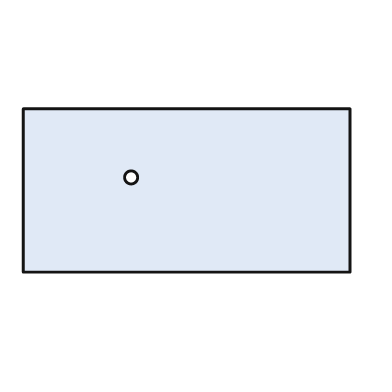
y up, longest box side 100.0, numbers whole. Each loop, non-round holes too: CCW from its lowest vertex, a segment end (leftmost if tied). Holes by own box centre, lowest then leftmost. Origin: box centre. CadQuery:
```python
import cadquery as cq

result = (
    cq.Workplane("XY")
    .moveTo(-50.0, -25.0)
    .lineTo(50.0, -25.0)
    .lineTo(50.0, 25.0)
    .lineTo(-50.0, 25.0)
    .close()
    .moveTo(-17.0, 4.0)
    .circle(2.0)
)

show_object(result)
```